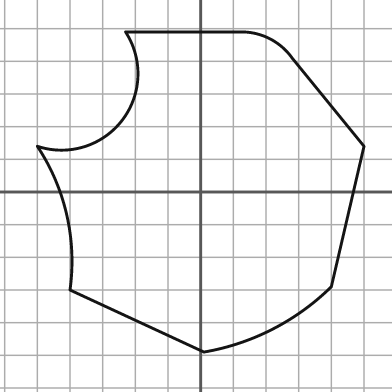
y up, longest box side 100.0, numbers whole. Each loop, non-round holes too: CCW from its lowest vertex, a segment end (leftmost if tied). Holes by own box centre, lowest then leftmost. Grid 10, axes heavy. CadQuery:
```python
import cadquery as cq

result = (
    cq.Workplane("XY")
    .moveTo(1.0, -49.0)
    .threePointArc((22.0, -42.0), (40.0, -29.0))
    .lineTo(50.0, 14.0)
    .lineTo(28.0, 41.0)
    .threePointArc((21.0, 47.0), (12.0, 49.0))
    .lineTo(-23.0, 49.0)
    .threePointArc((-24.0, 22.0), (-50.0, 14.0))
    .threePointArc((-41.0, -7.0), (-40.0, -30.0))
    .close()
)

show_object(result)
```